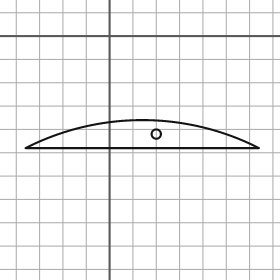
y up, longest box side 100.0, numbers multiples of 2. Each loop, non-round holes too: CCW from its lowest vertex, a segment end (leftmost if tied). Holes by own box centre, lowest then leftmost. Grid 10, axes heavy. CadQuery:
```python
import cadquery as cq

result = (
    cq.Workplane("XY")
    .moveTo(-36.0, -48.0)
    .lineTo(64.0, -48.0)
    .threePointArc((14.0, -36.0), (-36.0, -48.0))
    .close()
    .moveTo(20.0, -42.0)
    .circle(2.0)
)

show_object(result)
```